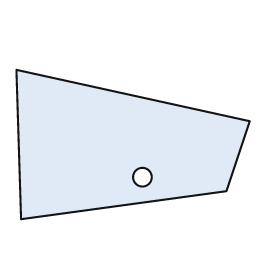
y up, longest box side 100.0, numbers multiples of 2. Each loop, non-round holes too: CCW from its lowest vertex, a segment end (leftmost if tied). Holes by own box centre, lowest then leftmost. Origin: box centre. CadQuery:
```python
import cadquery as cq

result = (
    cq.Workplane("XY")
    .moveTo(-48.0, -32.0)
    .lineTo(40.0, -20.0)
    .lineTo(50.0, 10.0)
    .lineTo(-50.0, 32.0)
    .close()
    .moveTo(4.0, -14.0)
    .circle(4.0)
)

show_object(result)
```